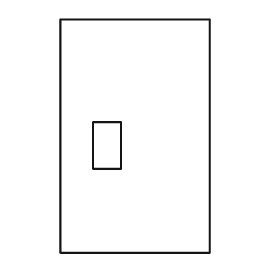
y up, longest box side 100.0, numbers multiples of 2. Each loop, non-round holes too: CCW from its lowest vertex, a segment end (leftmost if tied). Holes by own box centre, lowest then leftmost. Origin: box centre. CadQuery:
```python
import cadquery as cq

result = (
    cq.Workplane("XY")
    .moveTo(-32.0, -50.0)
    .lineTo(32.0, -50.0)
    .lineTo(32.0, 50.0)
    .lineTo(-32.0, 50.0)
    .close()
    .moveTo(-18.0, -14.0)
    .lineTo(-6.0, -14.0)
    .lineTo(-6.0, 6.0)
    .lineTo(-18.0, 6.0)
    .close()
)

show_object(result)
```